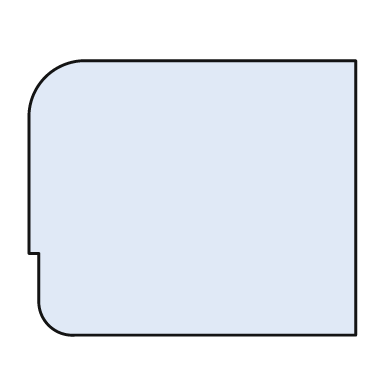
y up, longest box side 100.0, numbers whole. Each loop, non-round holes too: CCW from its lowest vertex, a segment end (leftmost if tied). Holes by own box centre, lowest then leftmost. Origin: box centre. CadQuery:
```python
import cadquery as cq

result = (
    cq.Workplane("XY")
    .moveTo(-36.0, -42.0)
    .lineTo(50.0, -42.0)
    .lineTo(50.0, 42.0)
    .lineTo(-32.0, 42.0)
    .threePointArc((-45.0, 37.0), (-50.0, 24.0))
    .lineTo(-50.0, -17.0)
    .lineTo(-47.0, -17.0)
    .lineTo(-47.0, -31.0)
    .threePointArc((-44.0, -39.0), (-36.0, -42.0))
    .close()
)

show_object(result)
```